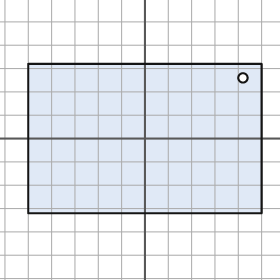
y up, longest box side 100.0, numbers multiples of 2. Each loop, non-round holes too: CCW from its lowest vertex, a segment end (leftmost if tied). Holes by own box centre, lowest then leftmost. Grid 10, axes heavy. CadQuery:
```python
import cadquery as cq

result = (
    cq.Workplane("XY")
    .moveTo(-50.0, -32.0)
    .lineTo(50.0, -32.0)
    .lineTo(50.0, 32.0)
    .lineTo(-50.0, 32.0)
    .close()
    .moveTo(42.0, 26.0)
    .circle(2.0)
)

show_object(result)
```